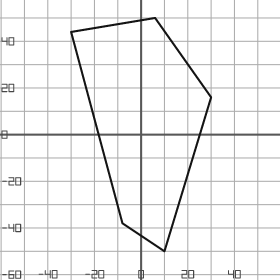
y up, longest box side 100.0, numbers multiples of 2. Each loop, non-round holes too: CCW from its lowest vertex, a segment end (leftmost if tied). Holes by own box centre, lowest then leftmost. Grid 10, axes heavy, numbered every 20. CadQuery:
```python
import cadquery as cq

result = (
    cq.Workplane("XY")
    .moveTo(10.0, -50.0)
    .lineTo(30.0, 16.0)
    .lineTo(6.0, 50.0)
    .lineTo(-30.0, 44.0)
    .lineTo(-8.0, -38.0)
    .close()
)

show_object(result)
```